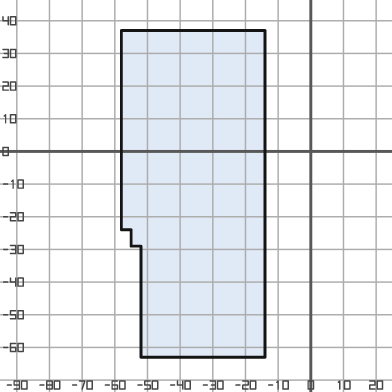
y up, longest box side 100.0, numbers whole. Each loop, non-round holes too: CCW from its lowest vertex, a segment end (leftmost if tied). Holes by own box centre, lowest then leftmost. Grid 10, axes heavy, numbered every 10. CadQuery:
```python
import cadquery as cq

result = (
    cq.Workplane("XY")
    .moveTo(-52.0, -63.0)
    .lineTo(-14.0, -63.0)
    .lineTo(-14.0, 37.0)
    .lineTo(-58.0, 37.0)
    .lineTo(-58.0, -24.0)
    .lineTo(-55.0, -24.0)
    .lineTo(-55.0, -29.0)
    .lineTo(-52.0, -29.0)
    .close()
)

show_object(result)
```